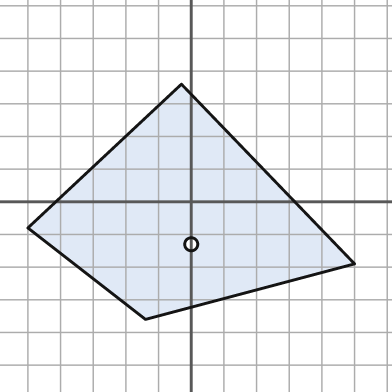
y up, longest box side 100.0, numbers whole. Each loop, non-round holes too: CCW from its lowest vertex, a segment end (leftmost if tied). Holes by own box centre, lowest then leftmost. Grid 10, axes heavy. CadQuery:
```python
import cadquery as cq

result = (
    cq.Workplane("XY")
    .moveTo(-14.0, -36.0)
    .lineTo(50.0, -19.0)
    .lineTo(-3.0, 36.0)
    .lineTo(-50.0, -8.0)
    .close()
    .moveTo(0.0, -13.0)
    .circle(2.0)
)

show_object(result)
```